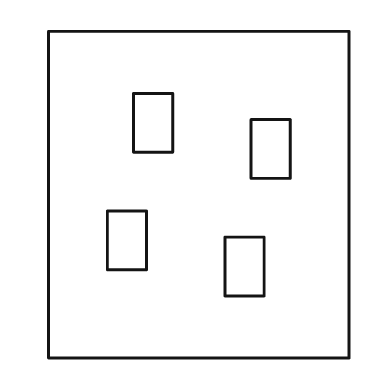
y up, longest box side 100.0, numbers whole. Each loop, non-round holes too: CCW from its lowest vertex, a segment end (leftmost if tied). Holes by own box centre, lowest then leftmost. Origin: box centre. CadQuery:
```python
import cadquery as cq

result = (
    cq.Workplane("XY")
    .moveTo(-46.0, -50.0)
    .lineTo(46.0, -50.0)
    .lineTo(46.0, 50.0)
    .lineTo(-46.0, 50.0)
    .close()
    .moveTo(8.0, -31.0)
    .lineTo(20.0, -31.0)
    .lineTo(20.0, -13.0)
    .lineTo(8.0, -13.0)
    .close()
    .moveTo(-28.0, -23.0)
    .lineTo(-16.0, -23.0)
    .lineTo(-16.0, -5.0)
    .lineTo(-28.0, -5.0)
    .close()
    .moveTo(16.0, 5.0)
    .lineTo(28.0, 5.0)
    .lineTo(28.0, 23.0)
    .lineTo(16.0, 23.0)
    .close()
    .moveTo(-20.0, 13.0)
    .lineTo(-8.0, 13.0)
    .lineTo(-8.0, 31.0)
    .lineTo(-20.0, 31.0)
    .close()
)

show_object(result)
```